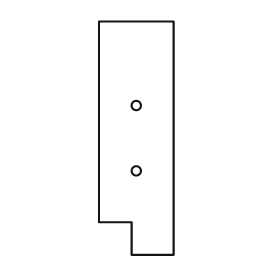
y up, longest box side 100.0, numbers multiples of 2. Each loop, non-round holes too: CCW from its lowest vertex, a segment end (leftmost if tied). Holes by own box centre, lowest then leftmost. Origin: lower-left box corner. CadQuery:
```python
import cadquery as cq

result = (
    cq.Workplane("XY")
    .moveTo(14.0, 0.0)
    .lineTo(32.0, 0.0)
    .lineTo(32.0, 100.0)
    .lineTo(0.0, 100.0)
    .lineTo(0.0, 14.0)
    .lineTo(14.0, 14.0)
    .close()
    .moveTo(16.0, 36.0)
    .circle(2.0)
    .moveTo(16.0, 64.0)
    .circle(2.0)
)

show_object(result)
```